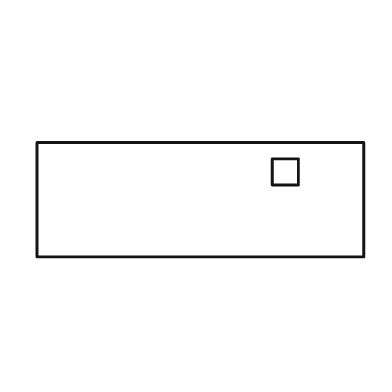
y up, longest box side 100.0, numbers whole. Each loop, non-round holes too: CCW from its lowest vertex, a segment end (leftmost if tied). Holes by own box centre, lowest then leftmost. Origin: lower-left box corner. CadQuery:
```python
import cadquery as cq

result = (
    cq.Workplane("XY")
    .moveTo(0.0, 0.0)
    .lineTo(100.0, 0.0)
    .lineTo(100.0, 35.0)
    .lineTo(0.0, 35.0)
    .close()
    .moveTo(72.0, 22.0)
    .lineTo(80.0, 22.0)
    .lineTo(80.0, 30.0)
    .lineTo(72.0, 30.0)
    .close()
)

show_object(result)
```